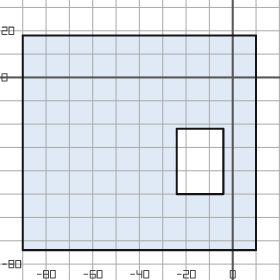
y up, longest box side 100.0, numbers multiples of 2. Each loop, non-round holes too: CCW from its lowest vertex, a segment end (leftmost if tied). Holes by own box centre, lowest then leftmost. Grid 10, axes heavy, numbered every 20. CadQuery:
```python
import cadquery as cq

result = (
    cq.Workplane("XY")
    .moveTo(-90.0, -74.0)
    .lineTo(10.0, -74.0)
    .lineTo(10.0, 18.0)
    .lineTo(-90.0, 18.0)
    .close()
    .moveTo(-24.0, -50.0)
    .lineTo(-4.0, -50.0)
    .lineTo(-4.0, -22.0)
    .lineTo(-24.0, -22.0)
    .close()
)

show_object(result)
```